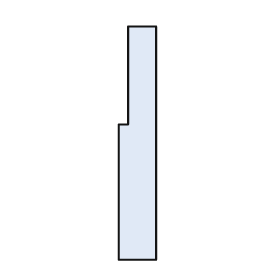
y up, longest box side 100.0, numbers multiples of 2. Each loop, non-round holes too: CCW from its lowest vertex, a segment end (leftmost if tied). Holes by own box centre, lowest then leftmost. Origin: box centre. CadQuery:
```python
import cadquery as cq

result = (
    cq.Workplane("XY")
    .moveTo(-8.0, -50.0)
    .lineTo(8.0, -50.0)
    .lineTo(8.0, 50.0)
    .lineTo(-4.0, 50.0)
    .lineTo(-4.0, 8.0)
    .lineTo(-8.0, 8.0)
    .close()
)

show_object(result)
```